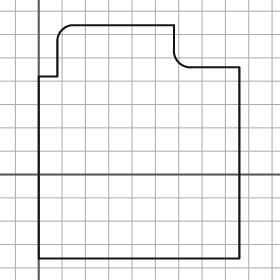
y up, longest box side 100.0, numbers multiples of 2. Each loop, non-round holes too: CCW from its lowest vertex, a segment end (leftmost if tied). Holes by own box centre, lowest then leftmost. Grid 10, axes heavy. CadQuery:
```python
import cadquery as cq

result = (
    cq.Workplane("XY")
    .moveTo(0.0, -36.0)
    .lineTo(86.0, -36.0)
    .lineTo(86.0, 46.0)
    .lineTo(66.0, 46.0)
    .threePointArc((60.0, 48.0), (58.0, 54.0))
    .lineTo(58.0, 64.0)
    .lineTo(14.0, 64.0)
    .threePointArc((10.0, 62.0), (8.0, 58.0))
    .lineTo(8.0, 42.0)
    .lineTo(0.0, 42.0)
    .close()
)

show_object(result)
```